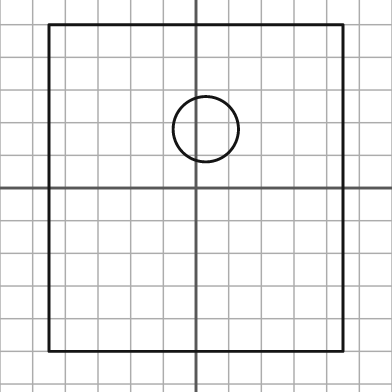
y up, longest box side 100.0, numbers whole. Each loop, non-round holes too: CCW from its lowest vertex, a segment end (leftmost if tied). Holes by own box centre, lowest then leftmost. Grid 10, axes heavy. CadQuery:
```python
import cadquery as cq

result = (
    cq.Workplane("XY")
    .moveTo(-45.0, -50.0)
    .lineTo(45.0, -50.0)
    .lineTo(45.0, 50.0)
    .lineTo(-45.0, 50.0)
    .close()
    .moveTo(3.0, 18.0)
    .circle(10.0)
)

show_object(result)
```